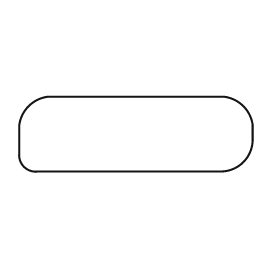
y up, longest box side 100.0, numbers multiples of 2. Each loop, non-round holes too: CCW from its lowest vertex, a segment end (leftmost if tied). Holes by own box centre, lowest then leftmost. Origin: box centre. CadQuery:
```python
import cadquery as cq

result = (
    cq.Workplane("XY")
    .moveTo(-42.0, -16.0)
    .lineTo(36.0, -16.0)
    .threePointArc((46.0, -12.0), (50.0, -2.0))
    .lineTo(50.0, 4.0)
    .threePointArc((46.0, 12.0), (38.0, 16.0))
    .lineTo(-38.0, 16.0)
    .threePointArc((-46.0, 12.0), (-50.0, 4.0))
    .lineTo(-50.0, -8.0)
    .threePointArc((-48.0, -14.0), (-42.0, -16.0))
    .close()
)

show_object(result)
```